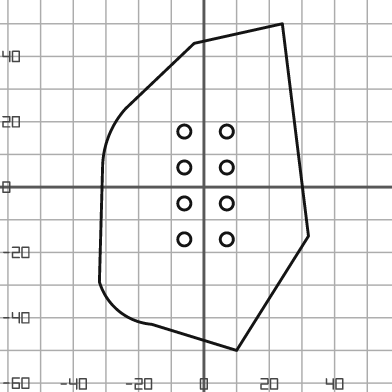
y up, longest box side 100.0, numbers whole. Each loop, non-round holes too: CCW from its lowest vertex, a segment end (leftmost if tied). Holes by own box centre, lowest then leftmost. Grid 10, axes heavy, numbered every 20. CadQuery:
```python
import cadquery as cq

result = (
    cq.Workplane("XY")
    .moveTo(10.0, -50.0)
    .lineTo(32.0, -15.0)
    .lineTo(24.0, 50.0)
    .lineTo(-3.0, 44.0)
    .lineTo(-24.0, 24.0)
    .threePointArc((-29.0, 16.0), (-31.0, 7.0))
    .lineTo(-32.0, -29.0)
    .threePointArc((-26.0, -38.0), (-16.0, -42.0))
    .close()
    .moveTo(-6.0, -16.0)
    .circle(2.0)
    .moveTo(7.0, -16.0)
    .circle(2.0)
    .moveTo(-6.0, -5.0)
    .circle(2.0)
    .moveTo(7.0, -5.0)
    .circle(2.0)
    .moveTo(-6.0, 6.0)
    .circle(2.0)
    .moveTo(7.0, 6.0)
    .circle(2.0)
    .moveTo(-6.0, 17.0)
    .circle(2.0)
    .moveTo(7.0, 17.0)
    .circle(2.0)
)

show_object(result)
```